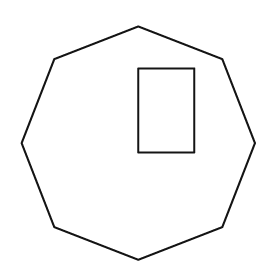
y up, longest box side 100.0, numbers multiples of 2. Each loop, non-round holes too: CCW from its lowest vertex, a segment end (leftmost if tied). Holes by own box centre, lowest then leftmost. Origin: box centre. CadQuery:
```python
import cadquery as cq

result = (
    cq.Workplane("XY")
    .moveTo(0.0, -50.0)
    .lineTo(36.0, -36.0)
    .lineTo(50.0, 0.0)
    .lineTo(36.0, 36.0)
    .lineTo(0.0, 50.0)
    .lineTo(-36.0, 36.0)
    .lineTo(-50.0, 0.0)
    .lineTo(-36.0, -36.0)
    .close()
    .moveTo(0.0, -4.0)
    .lineTo(24.0, -4.0)
    .lineTo(24.0, 32.0)
    .lineTo(0.0, 32.0)
    .close()
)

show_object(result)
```